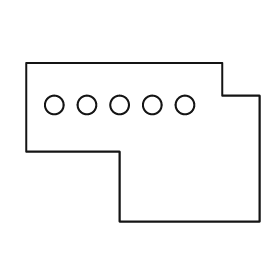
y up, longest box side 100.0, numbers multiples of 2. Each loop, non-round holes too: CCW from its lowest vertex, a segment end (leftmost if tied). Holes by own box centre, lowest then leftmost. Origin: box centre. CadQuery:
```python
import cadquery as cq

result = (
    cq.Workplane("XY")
    .moveTo(-10.0, -34.0)
    .lineTo(50.0, -34.0)
    .lineTo(50.0, 20.0)
    .lineTo(34.0, 20.0)
    .lineTo(34.0, 34.0)
    .lineTo(-50.0, 34.0)
    .lineTo(-50.0, -4.0)
    .lineTo(-10.0, -4.0)
    .close()
    .moveTo(-38.0, 16.0)
    .circle(4.0)
    .moveTo(-24.0, 16.0)
    .circle(4.0)
    .moveTo(-10.0, 16.0)
    .circle(4.0)
    .moveTo(4.0, 16.0)
    .circle(4.0)
    .moveTo(18.0, 16.0)
    .circle(4.0)
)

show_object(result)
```